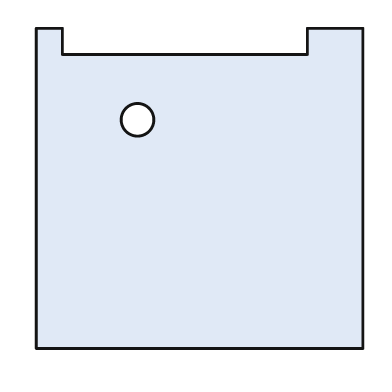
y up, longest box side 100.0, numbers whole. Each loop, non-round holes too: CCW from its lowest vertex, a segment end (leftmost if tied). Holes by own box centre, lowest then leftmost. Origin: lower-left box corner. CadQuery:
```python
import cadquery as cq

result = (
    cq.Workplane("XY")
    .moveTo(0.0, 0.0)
    .lineTo(100.0, 0.0)
    .lineTo(100.0, 98.0)
    .lineTo(83.0, 98.0)
    .lineTo(83.0, 90.0)
    .lineTo(8.0, 90.0)
    .lineTo(8.0, 98.0)
    .lineTo(0.0, 98.0)
    .close()
    .moveTo(31.0, 70.0)
    .circle(5.0)
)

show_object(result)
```